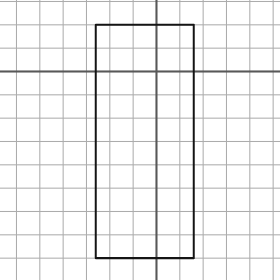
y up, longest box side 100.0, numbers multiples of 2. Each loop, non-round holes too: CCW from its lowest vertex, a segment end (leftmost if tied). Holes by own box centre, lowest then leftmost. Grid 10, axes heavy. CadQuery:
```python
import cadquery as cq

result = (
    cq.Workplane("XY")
    .moveTo(-26.0, -80.0)
    .lineTo(16.0, -80.0)
    .lineTo(16.0, 20.0)
    .lineTo(-26.0, 20.0)
    .close()
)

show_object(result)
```